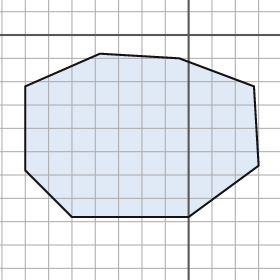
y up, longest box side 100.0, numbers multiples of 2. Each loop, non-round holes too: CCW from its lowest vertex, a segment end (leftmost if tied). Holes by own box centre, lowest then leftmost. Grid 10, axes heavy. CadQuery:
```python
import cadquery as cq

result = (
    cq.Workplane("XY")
    .moveTo(-50.0, -78.0)
    .lineTo(0.0, -78.0)
    .lineTo(30.0, -56.0)
    .lineTo(28.0, -22.0)
    .lineTo(-4.0, -10.0)
    .lineTo(-38.0, -8.0)
    .lineTo(-70.0, -22.0)
    .lineTo(-70.0, -58.0)
    .close()
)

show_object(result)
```